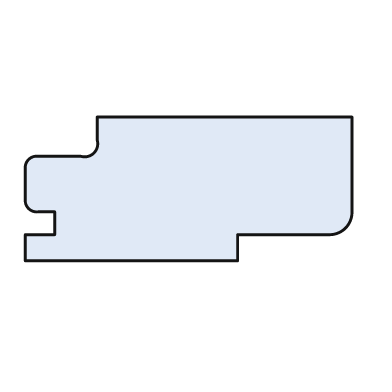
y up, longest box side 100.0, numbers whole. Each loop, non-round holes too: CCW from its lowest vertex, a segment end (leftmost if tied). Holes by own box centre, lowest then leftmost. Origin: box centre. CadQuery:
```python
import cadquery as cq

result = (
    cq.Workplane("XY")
    .moveTo(-50.0, -22.0)
    .lineTo(15.0, -22.0)
    .lineTo(15.0, -14.0)
    .lineTo(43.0, -14.0)
    .threePointArc((48.0, -12.0), (50.0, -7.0))
    .lineTo(50.0, 22.0)
    .lineTo(-28.0, 22.0)
    .lineTo(-28.0, 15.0)
    .threePointArc((-29.0, 11.0), (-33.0, 10.0))
    .lineTo(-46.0, 10.0)
    .threePointArc((-49.0, 9.0), (-50.0, 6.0))
    .lineTo(-50.0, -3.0)
    .threePointArc((-49.0, -6.0), (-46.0, -7.0))
    .lineTo(-41.0, -7.0)
    .lineTo(-41.0, -14.0)
    .lineTo(-50.0, -14.0)
    .close()
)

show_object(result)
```